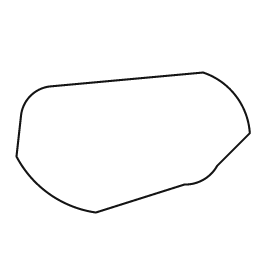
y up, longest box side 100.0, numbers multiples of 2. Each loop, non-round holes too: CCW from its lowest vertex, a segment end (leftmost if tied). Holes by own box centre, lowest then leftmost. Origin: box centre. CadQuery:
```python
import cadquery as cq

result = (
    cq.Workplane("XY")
    .moveTo(-16.0, -30.0)
    .lineTo(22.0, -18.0)
    .threePointArc((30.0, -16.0), (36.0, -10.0))
    .lineTo(50.0, 4.0)
    .threePointArc((44.0, 20.0), (30.0, 30.0))
    .lineTo(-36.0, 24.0)
    .threePointArc((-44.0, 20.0), (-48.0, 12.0))
    .lineTo(-50.0, -6.0)
    .threePointArc((-36.0, -22.0), (-16.0, -30.0))
    .close()
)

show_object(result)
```